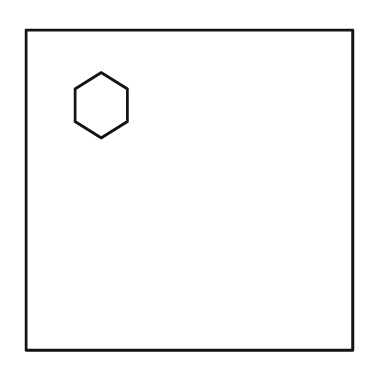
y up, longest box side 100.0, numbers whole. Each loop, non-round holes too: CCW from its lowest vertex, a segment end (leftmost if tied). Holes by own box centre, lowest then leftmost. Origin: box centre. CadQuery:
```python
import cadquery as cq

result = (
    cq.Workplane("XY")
    .moveTo(-50.0, -49.0)
    .lineTo(50.0, -49.0)
    .lineTo(50.0, 49.0)
    .lineTo(-50.0, 49.0)
    .close()
    .moveTo(-27.0, 16.0)
    .lineTo(-19.0, 21.0)
    .lineTo(-19.0, 31.0)
    .lineTo(-27.0, 36.0)
    .lineTo(-35.0, 31.0)
    .lineTo(-35.0, 21.0)
    .close()
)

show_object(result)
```